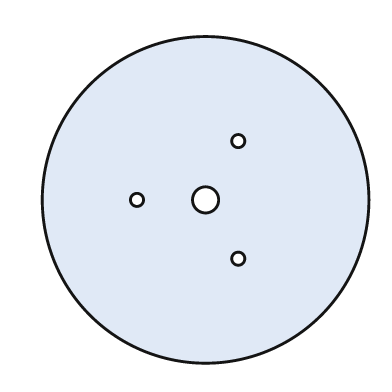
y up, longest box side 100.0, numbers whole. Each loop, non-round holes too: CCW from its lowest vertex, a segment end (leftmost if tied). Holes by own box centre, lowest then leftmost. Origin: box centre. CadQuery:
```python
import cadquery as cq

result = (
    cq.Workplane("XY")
    .moveTo(0.0, 0.0)
    .circle(50.0)
    .moveTo(10.0, -18.0)
    .circle(2.0)
    .moveTo(-21.0, 0.0)
    .circle(2.0)
    .moveTo(0.0, 0.0)
    .circle(4.0)
    .moveTo(10.0, 18.0)
    .circle(2.0)
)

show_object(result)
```